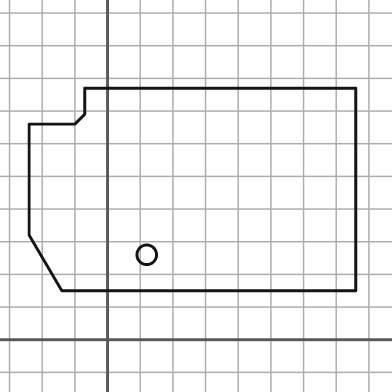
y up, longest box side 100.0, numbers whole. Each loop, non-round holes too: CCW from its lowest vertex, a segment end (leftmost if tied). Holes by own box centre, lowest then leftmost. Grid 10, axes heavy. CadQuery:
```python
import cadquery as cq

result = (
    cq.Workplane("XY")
    .moveTo(-14.0, 15.0)
    .lineTo(76.0, 15.0)
    .lineTo(76.0, 77.0)
    .lineTo(-7.0, 77.0)
    .lineTo(-7.0, 69.0)
    .lineTo(-10.0, 66.0)
    .lineTo(-24.0, 66.0)
    .lineTo(-24.0, 32.0)
    .close()
    .moveTo(12.0, 26.0)
    .circle(3.0)
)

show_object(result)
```